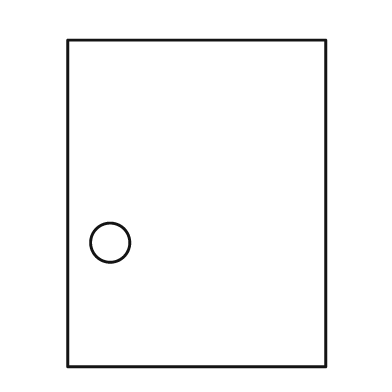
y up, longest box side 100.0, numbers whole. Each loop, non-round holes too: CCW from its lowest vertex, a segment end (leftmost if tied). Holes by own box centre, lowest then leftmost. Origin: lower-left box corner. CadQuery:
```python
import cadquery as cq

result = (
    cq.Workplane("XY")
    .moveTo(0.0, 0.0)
    .lineTo(79.0, 0.0)
    .lineTo(79.0, 100.0)
    .lineTo(0.0, 100.0)
    .close()
    .moveTo(13.0, 38.0)
    .circle(6.0)
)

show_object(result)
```